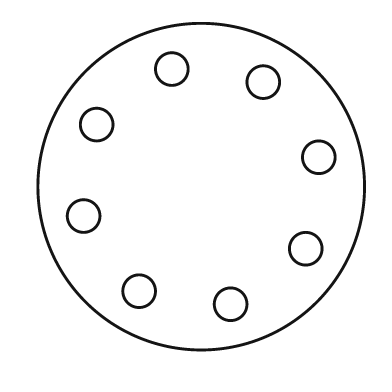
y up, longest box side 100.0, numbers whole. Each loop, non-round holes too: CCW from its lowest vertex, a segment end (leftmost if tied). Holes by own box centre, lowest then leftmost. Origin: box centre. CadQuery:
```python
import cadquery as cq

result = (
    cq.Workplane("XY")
    .moveTo(0.0, 0.0)
    .circle(50.0)
    .moveTo(9.0, -36.0)
    .circle(5.0)
    .moveTo(-19.0, -32.0)
    .circle(5.0)
    .moveTo(32.0, -19.0)
    .circle(5.0)
    .moveTo(-36.0, -9.0)
    .circle(5.0)
    .moveTo(36.0, 9.0)
    .circle(5.0)
    .moveTo(-32.0, 19.0)
    .circle(5.0)
    .moveTo(19.0, 32.0)
    .circle(5.0)
    .moveTo(-9.0, 36.0)
    .circle(5.0)
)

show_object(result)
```